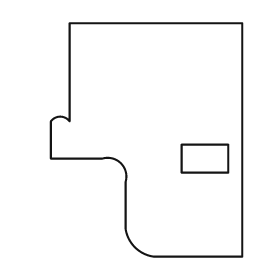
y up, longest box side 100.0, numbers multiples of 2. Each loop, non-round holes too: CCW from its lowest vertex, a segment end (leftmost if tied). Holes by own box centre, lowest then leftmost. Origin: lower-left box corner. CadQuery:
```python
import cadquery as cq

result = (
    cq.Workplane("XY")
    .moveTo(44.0, 0.0)
    .lineTo(82.0, 0.0)
    .lineTo(82.0, 100.0)
    .lineTo(8.0, 100.0)
    .lineTo(8.0, 58.0)
    .threePointArc((4.0, 60.0), (0.0, 58.0))
    .lineTo(0.0, 42.0)
    .lineTo(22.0, 42.0)
    .threePointArc((30.0, 40.0), (32.0, 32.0))
    .lineTo(32.0, 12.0)
    .threePointArc((36.0, 4.0), (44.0, 0.0))
    .close()
    .moveTo(56.0, 36.0)
    .lineTo(76.0, 36.0)
    .lineTo(76.0, 48.0)
    .lineTo(56.0, 48.0)
    .close()
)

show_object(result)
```